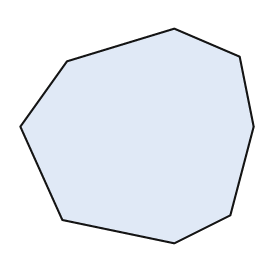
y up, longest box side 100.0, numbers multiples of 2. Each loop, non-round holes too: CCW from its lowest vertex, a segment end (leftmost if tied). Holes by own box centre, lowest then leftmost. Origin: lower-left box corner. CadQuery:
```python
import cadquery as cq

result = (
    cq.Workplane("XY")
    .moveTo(66.0, 0.0)
    .lineTo(90.0, 12.0)
    .lineTo(100.0, 50.0)
    .lineTo(94.0, 80.0)
    .lineTo(66.0, 92.0)
    .lineTo(20.0, 78.0)
    .lineTo(0.0, 50.0)
    .lineTo(18.0, 10.0)
    .close()
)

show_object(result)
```